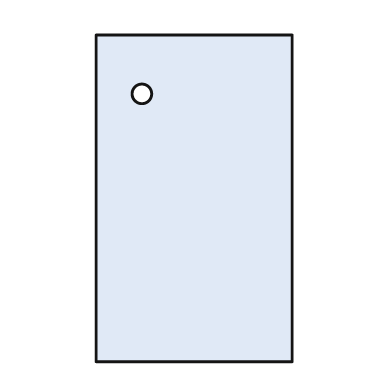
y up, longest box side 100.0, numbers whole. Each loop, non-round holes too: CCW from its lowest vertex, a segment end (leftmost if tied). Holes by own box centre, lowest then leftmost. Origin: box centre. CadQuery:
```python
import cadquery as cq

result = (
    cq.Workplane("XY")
    .moveTo(-30.0, -50.0)
    .lineTo(30.0, -50.0)
    .lineTo(30.0, 50.0)
    .lineTo(-30.0, 50.0)
    .close()
    .moveTo(-16.0, 32.0)
    .circle(3.0)
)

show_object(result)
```